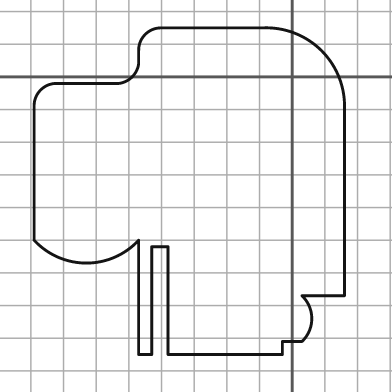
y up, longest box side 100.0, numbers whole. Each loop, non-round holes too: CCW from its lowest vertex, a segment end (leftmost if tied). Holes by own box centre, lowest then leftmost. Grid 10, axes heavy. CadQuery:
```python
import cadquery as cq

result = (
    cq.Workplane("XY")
    .moveTo(-47.0, -85.0)
    .lineTo(-43.0, -85.0)
    .lineTo(-43.0, -52.0)
    .lineTo(-38.0, -52.0)
    .lineTo(-38.0, -85.0)
    .lineTo(-3.0, -85.0)
    .lineTo(-3.0, -81.0)
    .lineTo(3.0, -81.0)
    .threePointArc((6.0, -74.0), (3.0, -67.0))
    .lineTo(16.0, -67.0)
    .lineTo(16.0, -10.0)
    .threePointArc((9.0, 8.0), (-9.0, 15.0))
    .lineTo(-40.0, 15.0)
    .threePointArc((-45.0, 13.0), (-47.0, 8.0))
    .lineTo(-47.0, 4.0)
    .threePointArc((-49.0, 0.0), (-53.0, -2.0))
    .lineTo(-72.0, -2.0)
    .threePointArc((-77.0, -4.0), (-79.0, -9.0))
    .lineTo(-79.0, -50.0)
    .threePointArc((-63.0, -57.0), (-47.0, -50.0))
    .close()
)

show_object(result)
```